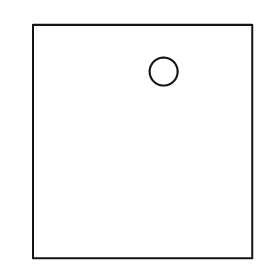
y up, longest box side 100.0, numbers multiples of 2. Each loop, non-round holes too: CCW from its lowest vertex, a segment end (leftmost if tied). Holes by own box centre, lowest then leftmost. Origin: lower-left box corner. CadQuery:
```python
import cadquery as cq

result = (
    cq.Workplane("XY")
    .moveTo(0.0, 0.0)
    .lineTo(94.0, 0.0)
    .lineTo(94.0, 100.0)
    .lineTo(0.0, 100.0)
    .close()
    .moveTo(56.0, 80.0)
    .circle(6.0)
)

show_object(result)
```